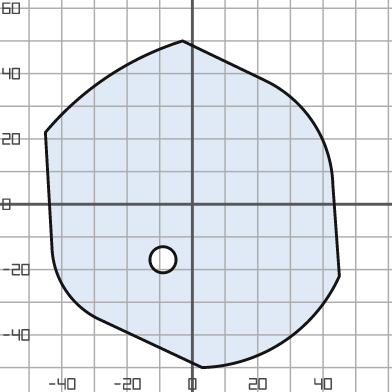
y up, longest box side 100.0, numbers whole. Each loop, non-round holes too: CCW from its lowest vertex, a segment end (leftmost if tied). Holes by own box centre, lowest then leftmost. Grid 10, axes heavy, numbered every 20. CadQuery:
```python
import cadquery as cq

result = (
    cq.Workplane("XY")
    .moveTo(3.0, -50.0)
    .threePointArc((28.0, -42.0), (45.0, -22.0))
    .lineTo(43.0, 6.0)
    .threePointArc((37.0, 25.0), (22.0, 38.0))
    .lineTo(-3.0, 50.0)
    .threePointArc((-26.0, 39.0), (-45.0, 22.0))
    .lineTo(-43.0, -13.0)
    .threePointArc((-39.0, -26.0), (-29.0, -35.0))
    .close()
    .moveTo(-9.0, -17.0)
    .circle(4.0)
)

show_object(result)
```